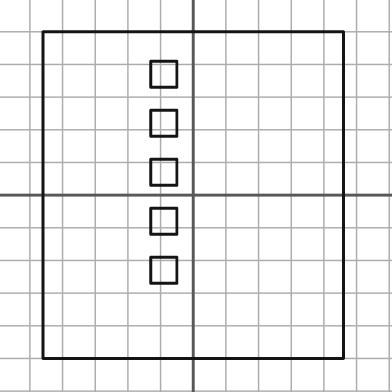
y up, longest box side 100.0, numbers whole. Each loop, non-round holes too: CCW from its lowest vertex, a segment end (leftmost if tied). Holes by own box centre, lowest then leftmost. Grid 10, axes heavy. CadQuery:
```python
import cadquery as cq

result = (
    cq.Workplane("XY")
    .moveTo(-46.0, -50.0)
    .lineTo(46.0, -50.0)
    .lineTo(46.0, 50.0)
    .lineTo(-46.0, 50.0)
    .close()
    .moveTo(-13.0, -27.0)
    .lineTo(-5.0, -27.0)
    .lineTo(-5.0, -19.0)
    .lineTo(-13.0, -19.0)
    .close()
    .moveTo(-13.0, -12.0)
    .lineTo(-5.0, -12.0)
    .lineTo(-5.0, -4.0)
    .lineTo(-13.0, -4.0)
    .close()
    .moveTo(-13.0, 3.0)
    .lineTo(-5.0, 3.0)
    .lineTo(-5.0, 11.0)
    .lineTo(-13.0, 11.0)
    .close()
    .moveTo(-13.0, 18.0)
    .lineTo(-5.0, 18.0)
    .lineTo(-5.0, 26.0)
    .lineTo(-13.0, 26.0)
    .close()
    .moveTo(-13.0, 33.0)
    .lineTo(-5.0, 33.0)
    .lineTo(-5.0, 41.0)
    .lineTo(-13.0, 41.0)
    .close()
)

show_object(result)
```